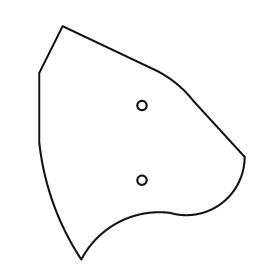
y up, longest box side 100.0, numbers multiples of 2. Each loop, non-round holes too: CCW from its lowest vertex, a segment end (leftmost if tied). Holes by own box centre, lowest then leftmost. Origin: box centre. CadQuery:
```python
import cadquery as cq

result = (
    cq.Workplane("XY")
    .moveTo(-26.0, -50.0)
    .threePointArc((-10.0, -34.0), (12.0, -30.0))
    .threePointArc((34.0, -26.0), (44.0, -6.0))
    .lineTo(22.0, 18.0)
    .threePointArc((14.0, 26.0), (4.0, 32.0))
    .lineTo(-34.0, 50.0)
    .lineTo(-44.0, 30.0)
    .lineTo(-44.0, 0.0)
    .threePointArc((-38.0, -26.0), (-26.0, -50.0))
    .close()
    .moveTo(0.0, -16.0)
    .circle(2.0)
    .moveTo(0.0, 16.0)
    .circle(2.0)
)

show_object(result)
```